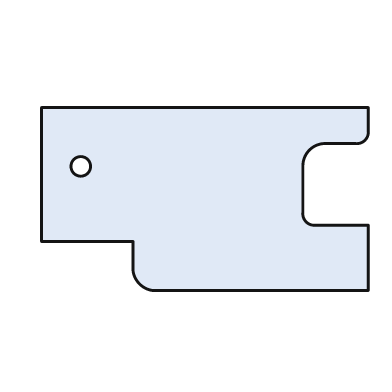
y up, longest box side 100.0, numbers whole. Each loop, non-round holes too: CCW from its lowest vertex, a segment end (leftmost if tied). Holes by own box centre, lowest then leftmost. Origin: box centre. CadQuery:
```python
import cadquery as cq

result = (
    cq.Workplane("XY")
    .moveTo(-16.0, -28.0)
    .lineTo(50.0, -28.0)
    .lineTo(50.0, -8.0)
    .lineTo(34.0, -8.0)
    .threePointArc((31.0, -7.0), (30.0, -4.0))
    .lineTo(30.0, 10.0)
    .threePointArc((32.0, 15.0), (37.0, 17.0))
    .lineTo(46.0, 17.0)
    .threePointArc((49.0, 18.0), (50.0, 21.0))
    .lineTo(50.0, 28.0)
    .lineTo(-50.0, 28.0)
    .lineTo(-50.0, -13.0)
    .lineTo(-22.0, -13.0)
    .lineTo(-22.0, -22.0)
    .threePointArc((-20.0, -26.0), (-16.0, -28.0))
    .close()
    .moveTo(-38.0, 10.0)
    .circle(3.0)
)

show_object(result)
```